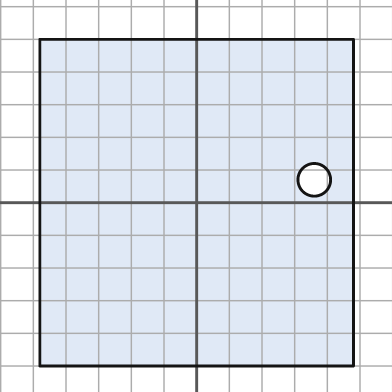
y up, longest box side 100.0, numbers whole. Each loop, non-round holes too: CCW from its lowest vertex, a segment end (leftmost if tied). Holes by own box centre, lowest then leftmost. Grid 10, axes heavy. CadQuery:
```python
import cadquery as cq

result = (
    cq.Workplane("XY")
    .moveTo(-48.0, -50.0)
    .lineTo(48.0, -50.0)
    .lineTo(48.0, 50.0)
    .lineTo(-48.0, 50.0)
    .close()
    .moveTo(36.0, 7.0)
    .circle(5.0)
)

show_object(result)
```